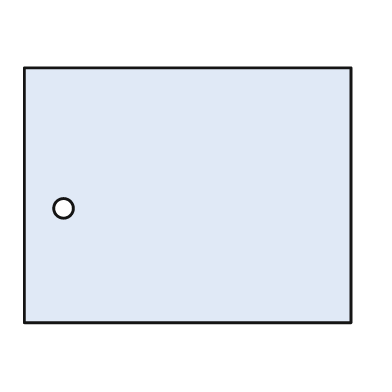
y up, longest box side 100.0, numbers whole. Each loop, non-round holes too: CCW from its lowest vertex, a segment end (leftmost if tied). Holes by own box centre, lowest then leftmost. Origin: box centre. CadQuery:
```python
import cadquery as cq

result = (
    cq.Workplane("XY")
    .moveTo(-50.0, -39.0)
    .lineTo(50.0, -39.0)
    .lineTo(50.0, 39.0)
    .lineTo(-50.0, 39.0)
    .close()
    .moveTo(-38.0, -4.0)
    .circle(3.0)
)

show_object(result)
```